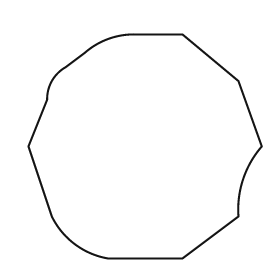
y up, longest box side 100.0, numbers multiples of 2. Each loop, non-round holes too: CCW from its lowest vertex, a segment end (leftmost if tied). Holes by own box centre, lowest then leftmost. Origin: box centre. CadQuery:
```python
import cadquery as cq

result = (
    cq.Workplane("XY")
    .moveTo(-16.0, -48.0)
    .lineTo(16.0, -48.0)
    .lineTo(40.0, -30.0)
    .threePointArc((42.0, -14.0), (50.0, 0.0))
    .lineTo(40.0, 28.0)
    .lineTo(16.0, 48.0)
    .lineTo(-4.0, 48.0)
    .threePointArc((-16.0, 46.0), (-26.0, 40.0))
    .lineTo(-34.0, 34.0)
    .threePointArc((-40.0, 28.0), (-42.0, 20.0))
    .lineTo(-50.0, 0.0)
    .lineTo(-40.0, -30.0)
    .threePointArc((-30.0, -42.0), (-16.0, -48.0))
    .close()
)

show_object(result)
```